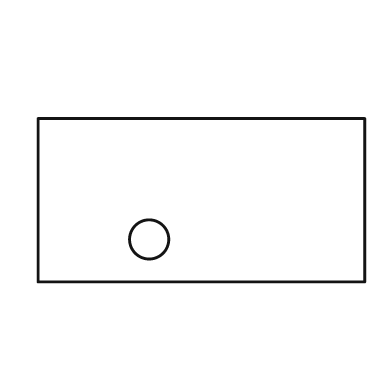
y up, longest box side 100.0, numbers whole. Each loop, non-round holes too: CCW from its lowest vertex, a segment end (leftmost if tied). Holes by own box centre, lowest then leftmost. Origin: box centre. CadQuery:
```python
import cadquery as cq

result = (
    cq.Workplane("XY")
    .moveTo(-50.0, -25.0)
    .lineTo(50.0, -25.0)
    .lineTo(50.0, 25.0)
    .lineTo(-50.0, 25.0)
    .close()
    .moveTo(-16.0, -12.0)
    .circle(6.0)
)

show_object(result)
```